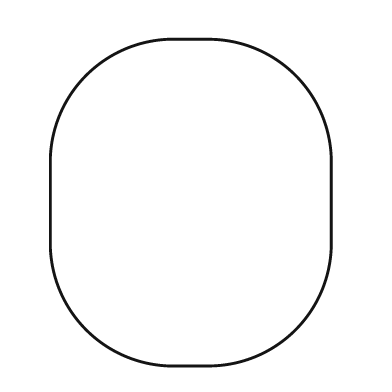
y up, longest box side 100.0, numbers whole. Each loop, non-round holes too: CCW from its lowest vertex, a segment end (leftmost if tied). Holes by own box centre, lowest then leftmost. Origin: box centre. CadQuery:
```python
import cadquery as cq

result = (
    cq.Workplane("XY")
    .moveTo(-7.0, -50.0)
    .lineTo(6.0, -50.0)
    .threePointArc((32.0, -39.0), (43.0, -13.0))
    .lineTo(43.0, 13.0)
    .threePointArc((32.0, 39.0), (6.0, 50.0))
    .lineTo(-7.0, 50.0)
    .threePointArc((-32.0, 39.0), (-43.0, 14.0))
    .lineTo(-43.0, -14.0)
    .threePointArc((-32.0, -39.0), (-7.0, -50.0))
    .close()
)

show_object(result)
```